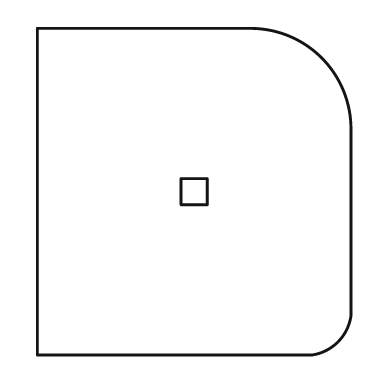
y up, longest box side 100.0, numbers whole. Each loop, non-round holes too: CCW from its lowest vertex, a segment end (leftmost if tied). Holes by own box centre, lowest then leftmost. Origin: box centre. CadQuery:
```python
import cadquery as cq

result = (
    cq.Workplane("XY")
    .moveTo(-48.0, -50.0)
    .lineTo(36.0, -50.0)
    .threePointArc((44.0, -46.0), (48.0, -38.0))
    .lineTo(48.0, 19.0)
    .threePointArc((39.0, 41.0), (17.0, 50.0))
    .lineTo(-48.0, 50.0)
    .close()
    .moveTo(-4.0, -4.0)
    .lineTo(4.0, -4.0)
    .lineTo(4.0, 4.0)
    .lineTo(-4.0, 4.0)
    .close()
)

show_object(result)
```